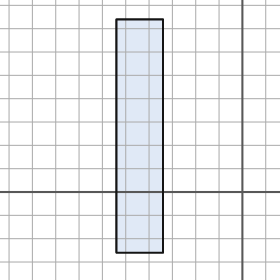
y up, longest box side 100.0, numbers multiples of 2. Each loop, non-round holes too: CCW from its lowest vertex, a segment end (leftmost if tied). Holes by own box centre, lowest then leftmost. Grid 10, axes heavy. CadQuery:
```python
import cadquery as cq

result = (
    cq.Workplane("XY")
    .moveTo(-54.0, -26.0)
    .lineTo(-34.0, -26.0)
    .lineTo(-34.0, 74.0)
    .lineTo(-54.0, 74.0)
    .close()
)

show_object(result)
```